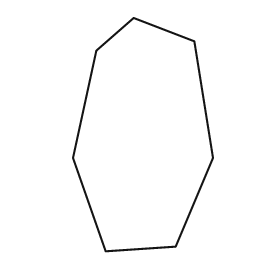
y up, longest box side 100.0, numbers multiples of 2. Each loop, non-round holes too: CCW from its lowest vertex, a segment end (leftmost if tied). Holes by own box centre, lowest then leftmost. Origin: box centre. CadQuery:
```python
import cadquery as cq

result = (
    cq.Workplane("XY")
    .moveTo(-16.0, -50.0)
    .lineTo(14.0, -48.0)
    .lineTo(30.0, -10.0)
    .lineTo(22.0, 40.0)
    .lineTo(-4.0, 50.0)
    .lineTo(-20.0, 36.0)
    .lineTo(-30.0, -10.0)
    .close()
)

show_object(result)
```